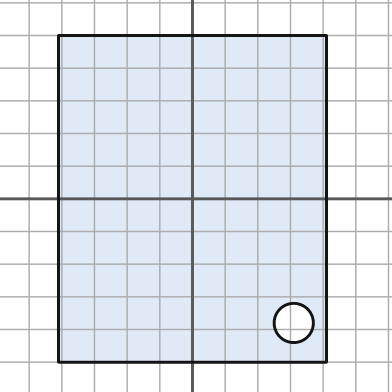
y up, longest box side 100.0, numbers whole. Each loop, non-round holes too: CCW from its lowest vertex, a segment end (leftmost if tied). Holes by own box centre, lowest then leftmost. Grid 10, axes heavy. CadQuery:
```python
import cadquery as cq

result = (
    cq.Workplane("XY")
    .moveTo(-41.0, -50.0)
    .lineTo(41.0, -50.0)
    .lineTo(41.0, 50.0)
    .lineTo(-41.0, 50.0)
    .close()
    .moveTo(31.0, -38.0)
    .circle(6.0)
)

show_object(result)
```